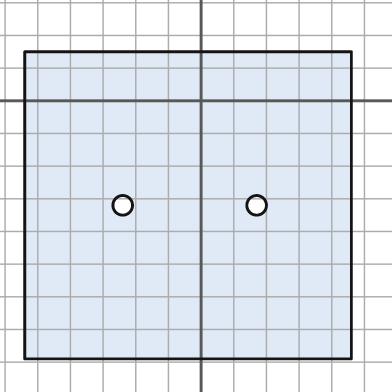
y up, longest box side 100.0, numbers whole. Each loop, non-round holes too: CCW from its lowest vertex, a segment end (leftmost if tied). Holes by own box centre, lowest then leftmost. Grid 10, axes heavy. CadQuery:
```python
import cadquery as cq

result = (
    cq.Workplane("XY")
    .moveTo(-54.0, -79.0)
    .lineTo(46.0, -79.0)
    .lineTo(46.0, 15.0)
    .lineTo(-54.0, 15.0)
    .close()
    .moveTo(-24.0, -32.0)
    .circle(3.0)
    .moveTo(17.0, -32.0)
    .circle(3.0)
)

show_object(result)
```